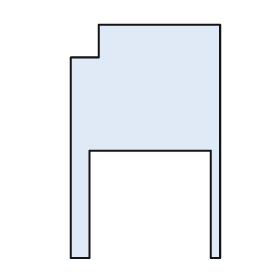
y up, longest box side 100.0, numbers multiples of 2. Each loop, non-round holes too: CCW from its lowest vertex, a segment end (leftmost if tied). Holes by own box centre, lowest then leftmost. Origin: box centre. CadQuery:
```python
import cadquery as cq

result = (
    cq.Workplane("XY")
    .moveTo(-32.0, -50.0)
    .lineTo(-24.0, -50.0)
    .lineTo(-24.0, -4.0)
    .lineTo(28.0, -4.0)
    .lineTo(28.0, -50.0)
    .lineTo(32.0, -50.0)
    .lineTo(32.0, 50.0)
    .lineTo(-20.0, 50.0)
    .lineTo(-20.0, 36.0)
    .lineTo(-32.0, 36.0)
    .close()
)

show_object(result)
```